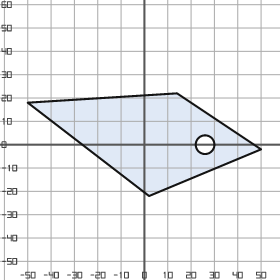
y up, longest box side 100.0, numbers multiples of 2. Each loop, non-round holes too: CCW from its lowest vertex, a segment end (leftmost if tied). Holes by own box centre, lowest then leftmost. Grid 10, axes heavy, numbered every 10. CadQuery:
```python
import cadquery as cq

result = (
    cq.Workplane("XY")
    .moveTo(2.0, -22.0)
    .lineTo(50.0, -2.0)
    .lineTo(14.0, 22.0)
    .lineTo(-50.0, 18.0)
    .close()
    .moveTo(26.0, 0.0)
    .circle(4.0)
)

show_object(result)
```